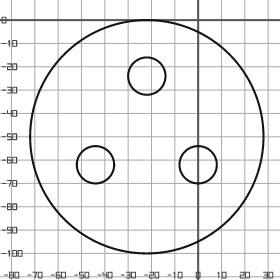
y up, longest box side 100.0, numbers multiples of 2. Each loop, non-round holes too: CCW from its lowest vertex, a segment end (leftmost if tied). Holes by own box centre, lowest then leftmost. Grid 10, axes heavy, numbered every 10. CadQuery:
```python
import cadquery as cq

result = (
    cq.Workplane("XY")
    .moveTo(-22.0, -50.0)
    .circle(50.0)
    .moveTo(-44.0, -62.0)
    .circle(8.0)
    .moveTo(0.0, -62.0)
    .circle(8.0)
    .moveTo(-22.0, -24.0)
    .circle(8.0)
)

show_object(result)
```